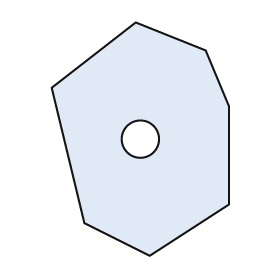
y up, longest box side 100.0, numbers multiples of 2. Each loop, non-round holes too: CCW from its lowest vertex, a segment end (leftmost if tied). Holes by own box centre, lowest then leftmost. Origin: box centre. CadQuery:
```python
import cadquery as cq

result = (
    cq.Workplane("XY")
    .moveTo(4.0, -50.0)
    .lineTo(38.0, -28.0)
    .lineTo(38.0, 14.0)
    .lineTo(28.0, 38.0)
    .lineTo(-2.0, 50.0)
    .lineTo(-38.0, 22.0)
    .lineTo(-24.0, -36.0)
    .close()
    .moveTo(0.0, 0.0)
    .circle(8.0)
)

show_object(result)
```